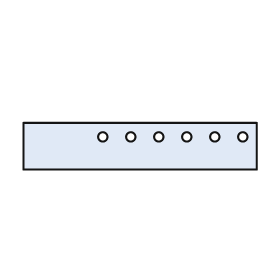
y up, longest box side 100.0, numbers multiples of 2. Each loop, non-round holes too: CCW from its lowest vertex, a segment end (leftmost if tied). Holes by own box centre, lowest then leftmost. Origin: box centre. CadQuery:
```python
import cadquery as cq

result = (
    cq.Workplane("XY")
    .moveTo(-50.0, -10.0)
    .lineTo(50.0, -10.0)
    .lineTo(50.0, 10.0)
    .lineTo(-50.0, 10.0)
    .close()
    .moveTo(-16.0, 4.0)
    .circle(2.0)
    .moveTo(-4.0, 4.0)
    .circle(2.0)
    .moveTo(8.0, 4.0)
    .circle(2.0)
    .moveTo(20.0, 4.0)
    .circle(2.0)
    .moveTo(32.0, 4.0)
    .circle(2.0)
    .moveTo(44.0, 4.0)
    .circle(2.0)
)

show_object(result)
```